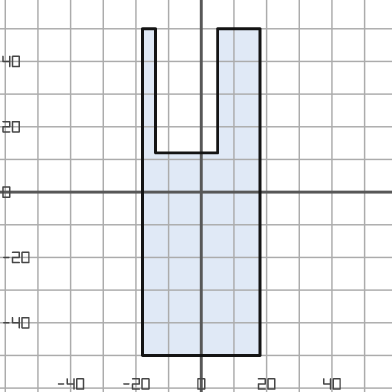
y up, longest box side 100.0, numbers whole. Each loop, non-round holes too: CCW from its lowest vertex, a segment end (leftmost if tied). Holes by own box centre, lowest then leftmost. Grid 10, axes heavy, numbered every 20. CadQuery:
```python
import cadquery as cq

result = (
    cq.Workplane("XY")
    .moveTo(-18.0, -50.0)
    .lineTo(18.0, -50.0)
    .lineTo(18.0, 50.0)
    .lineTo(5.0, 50.0)
    .lineTo(5.0, 12.0)
    .lineTo(-14.0, 12.0)
    .lineTo(-14.0, 50.0)
    .lineTo(-18.0, 50.0)
    .close()
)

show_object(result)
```